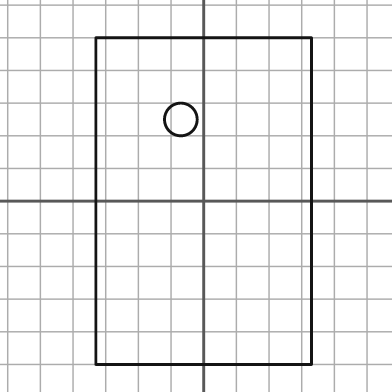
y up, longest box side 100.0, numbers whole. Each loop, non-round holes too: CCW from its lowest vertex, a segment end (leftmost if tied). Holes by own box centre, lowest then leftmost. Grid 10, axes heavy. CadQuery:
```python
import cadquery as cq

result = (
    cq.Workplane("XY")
    .moveTo(-33.0, -50.0)
    .lineTo(33.0, -50.0)
    .lineTo(33.0, 50.0)
    .lineTo(-33.0, 50.0)
    .close()
    .moveTo(-7.0, 25.0)
    .circle(5.0)
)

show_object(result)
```